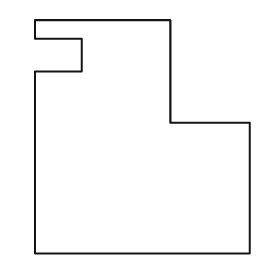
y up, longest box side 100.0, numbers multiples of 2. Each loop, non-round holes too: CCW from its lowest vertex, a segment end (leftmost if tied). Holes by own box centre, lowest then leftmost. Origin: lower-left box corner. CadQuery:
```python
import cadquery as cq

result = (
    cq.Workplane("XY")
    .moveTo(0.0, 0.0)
    .lineTo(92.0, 0.0)
    .lineTo(92.0, 56.0)
    .lineTo(58.0, 56.0)
    .lineTo(58.0, 100.0)
    .lineTo(0.0, 100.0)
    .lineTo(0.0, 92.0)
    .lineTo(20.0, 92.0)
    .lineTo(20.0, 78.0)
    .lineTo(0.0, 78.0)
    .close()
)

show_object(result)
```